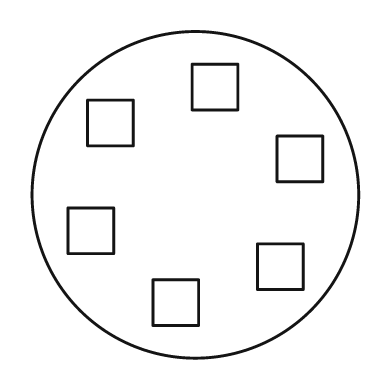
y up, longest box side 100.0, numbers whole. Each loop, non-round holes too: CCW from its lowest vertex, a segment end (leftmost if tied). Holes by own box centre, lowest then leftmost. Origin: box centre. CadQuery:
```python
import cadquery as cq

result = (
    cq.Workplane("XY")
    .moveTo(0.0, 0.0)
    .circle(50.0)
    .moveTo(-13.0, -40.0)
    .lineTo(1.0, -40.0)
    .lineTo(1.0, -26.0)
    .lineTo(-13.0, -26.0)
    .close()
    .moveTo(19.0, -29.0)
    .lineTo(33.0, -29.0)
    .lineTo(33.0, -15.0)
    .lineTo(19.0, -15.0)
    .close()
    .moveTo(-39.0, -18.0)
    .lineTo(-25.0, -18.0)
    .lineTo(-25.0, -4.0)
    .lineTo(-39.0, -4.0)
    .close()
    .moveTo(25.0, 4.0)
    .lineTo(39.0, 4.0)
    .lineTo(39.0, 18.0)
    .lineTo(25.0, 18.0)
    .close()
    .moveTo(-33.0, 15.0)
    .lineTo(-19.0, 15.0)
    .lineTo(-19.0, 29.0)
    .lineTo(-33.0, 29.0)
    .close()
    .moveTo(-1.0, 26.0)
    .lineTo(13.0, 26.0)
    .lineTo(13.0, 40.0)
    .lineTo(-1.0, 40.0)
    .close()
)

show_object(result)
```